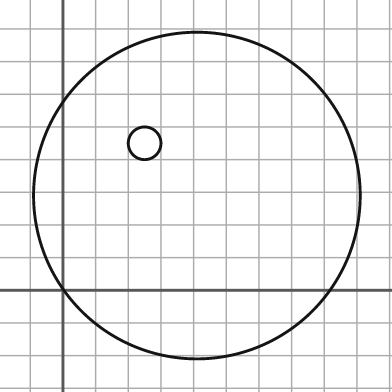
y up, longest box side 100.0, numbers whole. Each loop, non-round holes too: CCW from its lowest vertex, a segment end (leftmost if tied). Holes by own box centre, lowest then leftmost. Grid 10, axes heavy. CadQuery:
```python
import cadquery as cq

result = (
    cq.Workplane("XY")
    .moveTo(41.0, 29.0)
    .circle(50.0)
    .moveTo(25.0, 45.0)
    .circle(5.0)
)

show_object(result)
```